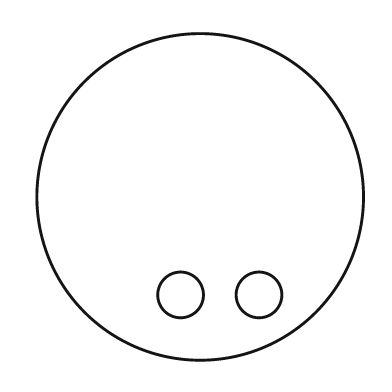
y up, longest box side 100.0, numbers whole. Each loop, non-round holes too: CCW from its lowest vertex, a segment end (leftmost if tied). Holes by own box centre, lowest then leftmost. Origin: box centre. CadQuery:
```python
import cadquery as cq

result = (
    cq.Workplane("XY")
    .moveTo(0.0, 0.0)
    .circle(50.0)
    .moveTo(-6.0, -30.0)
    .circle(7.0)
    .moveTo(18.0, -30.0)
    .circle(7.0)
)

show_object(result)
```